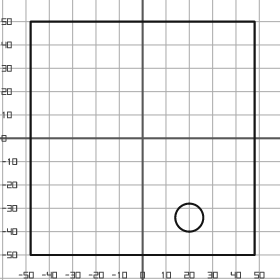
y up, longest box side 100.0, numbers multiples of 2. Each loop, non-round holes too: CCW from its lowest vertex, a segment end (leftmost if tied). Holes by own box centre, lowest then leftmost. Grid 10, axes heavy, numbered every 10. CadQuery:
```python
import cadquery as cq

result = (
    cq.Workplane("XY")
    .moveTo(-48.0, -50.0)
    .lineTo(48.0, -50.0)
    .lineTo(48.0, 50.0)
    .lineTo(-48.0, 50.0)
    .close()
    .moveTo(20.0, -34.0)
    .circle(6.0)
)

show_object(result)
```